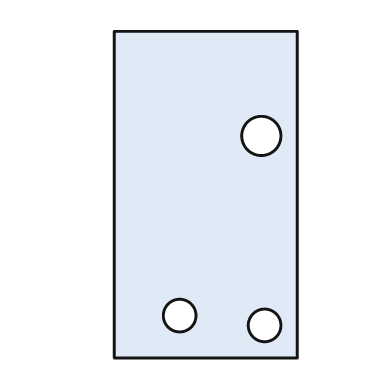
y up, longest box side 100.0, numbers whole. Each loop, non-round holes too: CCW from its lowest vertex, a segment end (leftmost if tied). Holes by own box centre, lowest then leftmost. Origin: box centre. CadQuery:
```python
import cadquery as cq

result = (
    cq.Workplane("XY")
    .moveTo(-28.0, -50.0)
    .lineTo(28.0, -50.0)
    .lineTo(28.0, 50.0)
    .lineTo(-28.0, 50.0)
    .close()
    .moveTo(18.0, -40.0)
    .circle(5.0)
    .moveTo(-8.0, -37.0)
    .circle(5.0)
    .moveTo(17.0, 18.0)
    .circle(6.0)
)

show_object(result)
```